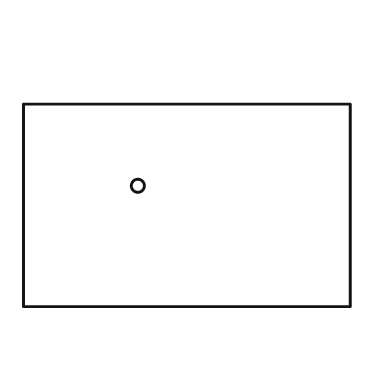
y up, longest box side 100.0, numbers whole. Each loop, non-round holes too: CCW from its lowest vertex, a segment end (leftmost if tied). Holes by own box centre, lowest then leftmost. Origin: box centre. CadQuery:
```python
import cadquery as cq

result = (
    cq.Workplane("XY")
    .moveTo(-50.0, -31.0)
    .lineTo(50.0, -31.0)
    .lineTo(50.0, 31.0)
    .lineTo(-50.0, 31.0)
    .close()
    .moveTo(-15.0, 6.0)
    .circle(2.0)
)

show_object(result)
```